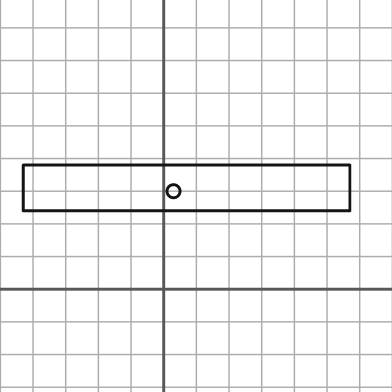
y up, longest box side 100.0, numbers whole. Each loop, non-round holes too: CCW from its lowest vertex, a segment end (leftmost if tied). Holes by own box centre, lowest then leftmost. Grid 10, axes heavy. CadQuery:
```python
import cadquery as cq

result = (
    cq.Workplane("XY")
    .moveTo(-43.0, 24.0)
    .lineTo(57.0, 24.0)
    .lineTo(57.0, 38.0)
    .lineTo(-43.0, 38.0)
    .close()
    .moveTo(3.0, 30.0)
    .circle(2.0)
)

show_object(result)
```